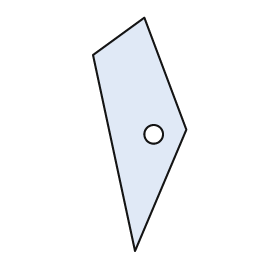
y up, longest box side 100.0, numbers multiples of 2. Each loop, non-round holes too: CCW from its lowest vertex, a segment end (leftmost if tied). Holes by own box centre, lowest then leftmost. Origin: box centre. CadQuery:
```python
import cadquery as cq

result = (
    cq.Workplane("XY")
    .moveTo(-2.0, -50.0)
    .lineTo(20.0, 2.0)
    .lineTo(2.0, 50.0)
    .lineTo(-20.0, 34.0)
    .close()
    .moveTo(6.0, 0.0)
    .circle(4.0)
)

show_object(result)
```